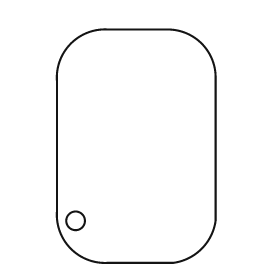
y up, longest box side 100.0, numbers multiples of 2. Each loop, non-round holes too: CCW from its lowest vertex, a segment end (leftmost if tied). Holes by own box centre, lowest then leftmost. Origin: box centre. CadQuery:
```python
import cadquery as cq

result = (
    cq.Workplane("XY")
    .moveTo(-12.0, -50.0)
    .lineTo(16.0, -50.0)
    .threePointArc((28.0, -44.0), (34.0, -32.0))
    .lineTo(34.0, 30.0)
    .threePointArc((28.0, 44.0), (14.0, 50.0))
    .lineTo(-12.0, 50.0)
    .threePointArc((-28.0, 44.0), (-34.0, 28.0))
    .lineTo(-34.0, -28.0)
    .threePointArc((-28.0, -44.0), (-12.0, -50.0))
    .close()
    .moveTo(-26.0, -32.0)
    .circle(4.0)
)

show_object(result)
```